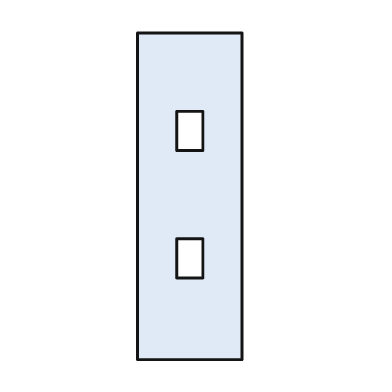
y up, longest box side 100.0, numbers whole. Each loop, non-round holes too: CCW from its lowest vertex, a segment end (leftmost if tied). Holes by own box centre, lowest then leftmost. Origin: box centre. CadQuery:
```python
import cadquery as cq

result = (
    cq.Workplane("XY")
    .moveTo(-16.0, -50.0)
    .lineTo(16.0, -50.0)
    .lineTo(16.0, 50.0)
    .lineTo(-16.0, 50.0)
    .close()
    .moveTo(-4.0, -25.0)
    .lineTo(4.0, -25.0)
    .lineTo(4.0, -13.0)
    .lineTo(-4.0, -13.0)
    .close()
    .moveTo(-4.0, 14.0)
    .lineTo(4.0, 14.0)
    .lineTo(4.0, 26.0)
    .lineTo(-4.0, 26.0)
    .close()
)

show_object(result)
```